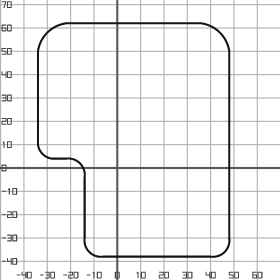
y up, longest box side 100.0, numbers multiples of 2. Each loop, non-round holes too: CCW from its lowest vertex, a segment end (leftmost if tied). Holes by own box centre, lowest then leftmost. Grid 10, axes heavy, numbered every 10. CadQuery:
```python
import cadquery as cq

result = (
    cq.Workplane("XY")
    .moveTo(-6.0, -38.0)
    .lineTo(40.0, -38.0)
    .threePointArc((46.0, -36.0), (48.0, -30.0))
    .lineTo(48.0, 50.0)
    .threePointArc((44.0, 58.0), (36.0, 62.0))
    .lineTo(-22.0, 62.0)
    .threePointArc((-30.0, 58.0), (-34.0, 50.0))
    .lineTo(-34.0, 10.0)
    .threePointArc((-32.0, 6.0), (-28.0, 4.0))
    .lineTo(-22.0, 4.0)
    .threePointArc((-16.0, 2.0), (-14.0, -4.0))
    .lineTo(-14.0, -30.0)
    .threePointArc((-12.0, -36.0), (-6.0, -38.0))
    .close()
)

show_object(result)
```